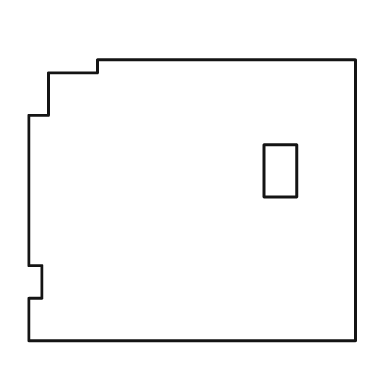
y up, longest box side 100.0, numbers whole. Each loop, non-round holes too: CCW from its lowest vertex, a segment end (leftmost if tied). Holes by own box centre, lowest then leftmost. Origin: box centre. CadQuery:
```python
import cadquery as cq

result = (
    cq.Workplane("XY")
    .moveTo(-50.0, -43.0)
    .lineTo(50.0, -43.0)
    .lineTo(50.0, 43.0)
    .lineTo(-29.0, 43.0)
    .lineTo(-29.0, 39.0)
    .lineTo(-44.0, 39.0)
    .lineTo(-44.0, 26.0)
    .lineTo(-50.0, 26.0)
    .lineTo(-50.0, -20.0)
    .lineTo(-46.0, -20.0)
    .lineTo(-46.0, -30.0)
    .lineTo(-50.0, -30.0)
    .close()
    .moveTo(22.0, 1.0)
    .lineTo(32.0, 1.0)
    .lineTo(32.0, 17.0)
    .lineTo(22.0, 17.0)
    .close()
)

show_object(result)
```